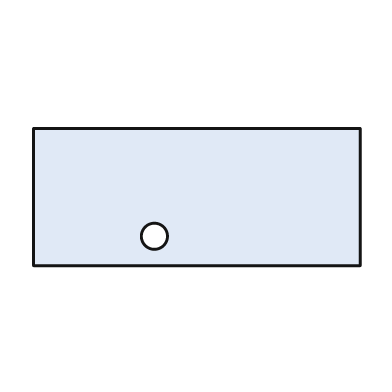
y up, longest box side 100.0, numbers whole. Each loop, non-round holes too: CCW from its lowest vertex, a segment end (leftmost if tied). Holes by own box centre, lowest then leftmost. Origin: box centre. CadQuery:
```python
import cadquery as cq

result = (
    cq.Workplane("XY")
    .moveTo(-50.0, -21.0)
    .lineTo(50.0, -21.0)
    .lineTo(50.0, 21.0)
    .lineTo(-50.0, 21.0)
    .close()
    .moveTo(-13.0, -12.0)
    .circle(4.0)
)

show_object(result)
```